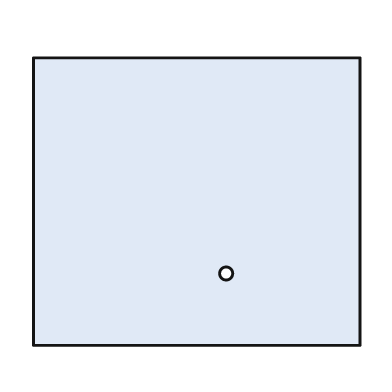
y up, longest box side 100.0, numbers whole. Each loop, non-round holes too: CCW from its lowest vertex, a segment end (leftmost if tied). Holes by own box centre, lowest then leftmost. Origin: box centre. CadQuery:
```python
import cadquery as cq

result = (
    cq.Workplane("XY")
    .moveTo(-50.0, -44.0)
    .lineTo(50.0, -44.0)
    .lineTo(50.0, 44.0)
    .lineTo(-50.0, 44.0)
    .close()
    .moveTo(9.0, -22.0)
    .circle(2.0)
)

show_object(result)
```